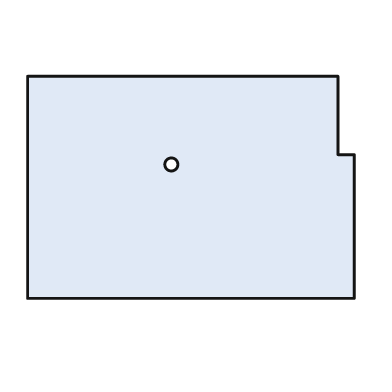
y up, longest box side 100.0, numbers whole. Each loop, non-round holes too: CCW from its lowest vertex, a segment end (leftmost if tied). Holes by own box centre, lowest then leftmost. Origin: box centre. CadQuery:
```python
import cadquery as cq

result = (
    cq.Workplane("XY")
    .moveTo(-50.0, -34.0)
    .lineTo(50.0, -34.0)
    .lineTo(50.0, 10.0)
    .lineTo(45.0, 10.0)
    .lineTo(45.0, 34.0)
    .lineTo(-50.0, 34.0)
    .close()
    .moveTo(-6.0, 7.0)
    .circle(2.0)
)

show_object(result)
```